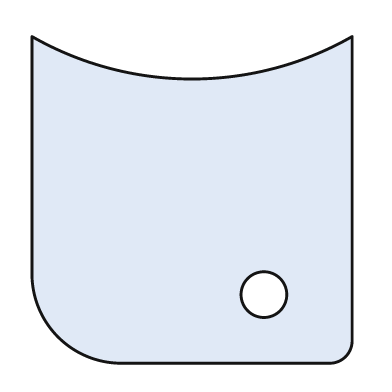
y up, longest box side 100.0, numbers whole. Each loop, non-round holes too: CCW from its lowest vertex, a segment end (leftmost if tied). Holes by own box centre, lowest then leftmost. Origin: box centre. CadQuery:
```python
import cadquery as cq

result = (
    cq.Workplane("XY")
    .moveTo(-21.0, -50.0)
    .lineTo(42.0, -50.0)
    .threePointArc((47.0, -48.0), (49.0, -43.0))
    .lineTo(49.0, 50.0)
    .threePointArc((0.0, 37.0), (-49.0, 50.0))
    .lineTo(-49.0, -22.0)
    .threePointArc((-41.0, -42.0), (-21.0, -50.0))
    .close()
    .moveTo(22.0, -29.0)
    .circle(7.0)
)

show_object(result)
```